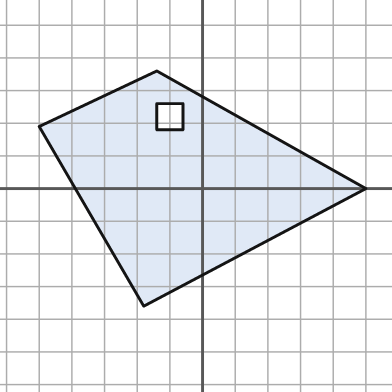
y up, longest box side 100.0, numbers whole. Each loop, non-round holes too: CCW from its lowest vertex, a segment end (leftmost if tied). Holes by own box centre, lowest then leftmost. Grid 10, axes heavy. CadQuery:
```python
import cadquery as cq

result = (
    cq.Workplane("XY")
    .moveTo(-18.0, -36.0)
    .lineTo(50.0, 0.0)
    .lineTo(-14.0, 36.0)
    .lineTo(-50.0, 19.0)
    .close()
    .moveTo(-14.0, 18.0)
    .lineTo(-6.0, 18.0)
    .lineTo(-6.0, 26.0)
    .lineTo(-14.0, 26.0)
    .close()
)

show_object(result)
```